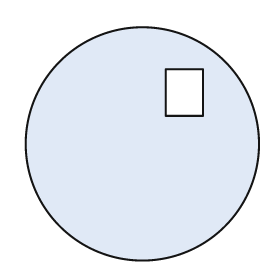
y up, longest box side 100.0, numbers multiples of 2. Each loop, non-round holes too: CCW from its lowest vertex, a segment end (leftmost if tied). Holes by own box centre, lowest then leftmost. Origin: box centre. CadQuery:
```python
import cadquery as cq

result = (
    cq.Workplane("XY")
    .moveTo(0.0, 0.0)
    .circle(50.0)
    .moveTo(10.0, 12.0)
    .lineTo(26.0, 12.0)
    .lineTo(26.0, 32.0)
    .lineTo(10.0, 32.0)
    .close()
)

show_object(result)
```